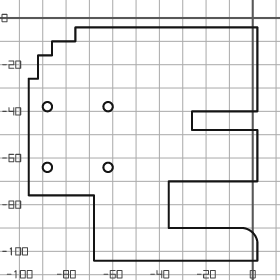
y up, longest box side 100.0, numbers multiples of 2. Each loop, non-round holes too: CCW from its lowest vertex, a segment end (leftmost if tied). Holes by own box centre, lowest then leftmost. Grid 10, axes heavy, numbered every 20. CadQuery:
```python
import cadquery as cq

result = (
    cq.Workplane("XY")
    .moveTo(-68.0, -104.0)
    .lineTo(2.0, -104.0)
    .lineTo(2.0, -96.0)
    .threePointArc((0.0, -92.0), (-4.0, -90.0))
    .lineTo(-36.0, -90.0)
    .lineTo(-36.0, -70.0)
    .lineTo(2.0, -70.0)
    .lineTo(2.0, -48.0)
    .lineTo(-26.0, -48.0)
    .lineTo(-26.0, -40.0)
    .lineTo(2.0, -40.0)
    .lineTo(2.0, -4.0)
    .lineTo(-76.0, -4.0)
    .lineTo(-76.0, -10.0)
    .lineTo(-86.0, -10.0)
    .lineTo(-86.0, -16.0)
    .lineTo(-92.0, -16.0)
    .lineTo(-92.0, -26.0)
    .lineTo(-96.0, -26.0)
    .lineTo(-96.0, -76.0)
    .lineTo(-68.0, -76.0)
    .close()
    .moveTo(-88.0, -64.0)
    .circle(2.0)
    .moveTo(-62.0, -64.0)
    .circle(2.0)
    .moveTo(-88.0, -38.0)
    .circle(2.0)
    .moveTo(-62.0, -38.0)
    .circle(2.0)
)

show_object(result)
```